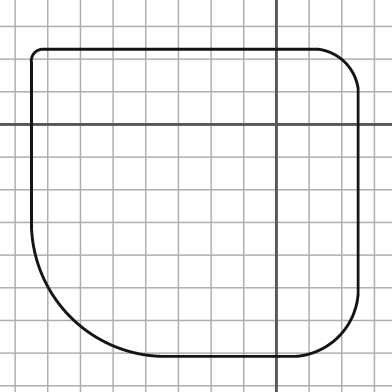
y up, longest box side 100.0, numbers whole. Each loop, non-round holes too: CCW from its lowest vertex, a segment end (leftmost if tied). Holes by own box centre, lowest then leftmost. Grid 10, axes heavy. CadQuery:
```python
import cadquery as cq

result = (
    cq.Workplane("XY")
    .moveTo(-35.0, -71.0)
    .lineTo(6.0, -71.0)
    .threePointArc((19.0, -65.0), (25.0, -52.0))
    .lineTo(25.0, 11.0)
    .threePointArc((21.0, 19.0), (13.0, 23.0))
    .lineTo(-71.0, 23.0)
    .threePointArc((-74.0, 22.0), (-75.0, 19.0))
    .lineTo(-75.0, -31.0)
    .threePointArc((-63.0, -59.0), (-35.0, -71.0))
    .close()
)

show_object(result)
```